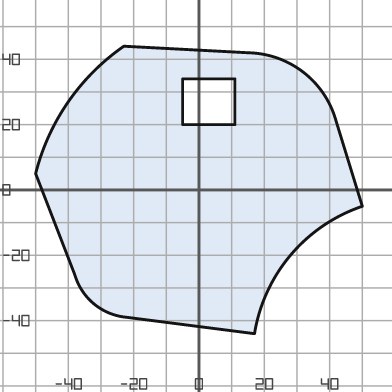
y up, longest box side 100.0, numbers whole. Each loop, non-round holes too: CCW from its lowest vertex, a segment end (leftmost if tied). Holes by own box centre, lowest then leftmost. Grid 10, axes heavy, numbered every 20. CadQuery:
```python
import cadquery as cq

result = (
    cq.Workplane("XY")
    .moveTo(17.0, -44.0)
    .threePointArc((28.0, -20.0), (50.0, -5.0))
    .lineTo(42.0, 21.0)
    .threePointArc((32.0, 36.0), (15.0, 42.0))
    .lineTo(-23.0, 44.0)
    .threePointArc((-40.0, 27.0), (-50.0, 5.0))
    .lineTo(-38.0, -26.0)
    .threePointArc((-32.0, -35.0), (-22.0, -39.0))
    .close()
    .moveTo(-5.0, 20.0)
    .lineTo(11.0, 20.0)
    .lineTo(11.0, 34.0)
    .lineTo(-5.0, 34.0)
    .close()
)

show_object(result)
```